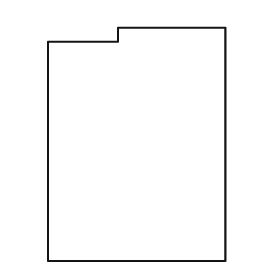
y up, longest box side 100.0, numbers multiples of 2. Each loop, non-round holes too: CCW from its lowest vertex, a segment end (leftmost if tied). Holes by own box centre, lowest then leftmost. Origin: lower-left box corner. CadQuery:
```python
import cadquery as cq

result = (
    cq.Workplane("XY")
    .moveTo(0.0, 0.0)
    .lineTo(76.0, 0.0)
    .lineTo(76.0, 100.0)
    .lineTo(30.0, 100.0)
    .lineTo(30.0, 94.0)
    .lineTo(0.0, 94.0)
    .close()
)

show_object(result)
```